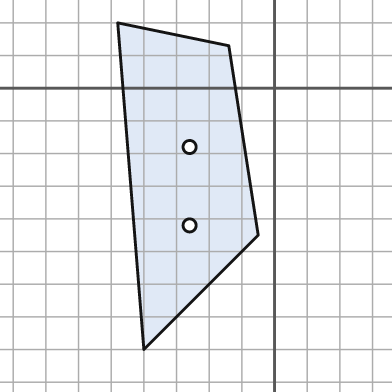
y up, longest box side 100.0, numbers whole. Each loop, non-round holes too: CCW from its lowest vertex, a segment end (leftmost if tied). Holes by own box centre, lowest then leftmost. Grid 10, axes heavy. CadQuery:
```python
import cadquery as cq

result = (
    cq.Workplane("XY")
    .moveTo(-40.0, -80.0)
    .lineTo(-5.0, -45.0)
    .lineTo(-14.0, 13.0)
    .lineTo(-48.0, 20.0)
    .close()
    .moveTo(-26.0, -42.0)
    .circle(2.0)
    .moveTo(-26.0, -18.0)
    .circle(2.0)
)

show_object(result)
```